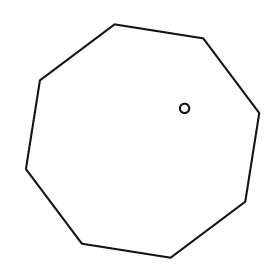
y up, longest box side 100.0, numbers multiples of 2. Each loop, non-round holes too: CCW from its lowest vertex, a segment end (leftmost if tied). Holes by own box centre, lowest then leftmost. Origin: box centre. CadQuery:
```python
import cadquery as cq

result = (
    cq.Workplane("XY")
    .moveTo(12.0, -50.0)
    .lineTo(44.0, -26.0)
    .lineTo(50.0, 12.0)
    .lineTo(26.0, 44.0)
    .lineTo(-12.0, 50.0)
    .lineTo(-44.0, 26.0)
    .lineTo(-50.0, -12.0)
    .lineTo(-26.0, -44.0)
    .close()
    .moveTo(18.0, 14.0)
    .circle(2.0)
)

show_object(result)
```